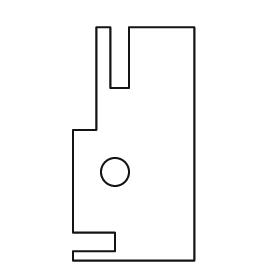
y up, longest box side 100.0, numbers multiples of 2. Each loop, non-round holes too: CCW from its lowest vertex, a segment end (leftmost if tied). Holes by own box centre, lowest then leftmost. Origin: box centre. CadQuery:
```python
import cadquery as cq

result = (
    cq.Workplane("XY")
    .moveTo(-26.0, -50.0)
    .lineTo(26.0, -50.0)
    .lineTo(26.0, 50.0)
    .lineTo(-2.0, 50.0)
    .lineTo(-2.0, 24.0)
    .lineTo(-10.0, 24.0)
    .lineTo(-10.0, 50.0)
    .lineTo(-16.0, 50.0)
    .lineTo(-16.0, 6.0)
    .lineTo(-26.0, 6.0)
    .lineTo(-26.0, -38.0)
    .lineTo(-8.0, -38.0)
    .lineTo(-8.0, -46.0)
    .lineTo(-26.0, -46.0)
    .close()
    .moveTo(-8.0, -12.0)
    .circle(6.0)
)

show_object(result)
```